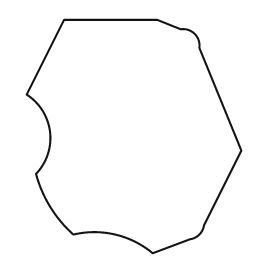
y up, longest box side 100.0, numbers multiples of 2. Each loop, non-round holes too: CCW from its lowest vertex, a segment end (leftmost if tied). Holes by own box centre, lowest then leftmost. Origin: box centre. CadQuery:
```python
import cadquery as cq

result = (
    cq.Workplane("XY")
    .moveTo(8.0, -50.0)
    .lineTo(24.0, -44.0)
    .threePointArc((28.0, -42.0), (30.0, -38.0))
    .lineTo(46.0, -6.0)
    .lineTo(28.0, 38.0)
    .threePointArc((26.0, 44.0), (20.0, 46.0))
    .lineTo(10.0, 50.0)
    .lineTo(-30.0, 50.0)
    .lineTo(-46.0, 18.0)
    .threePointArc((-36.0, 2.0), (-42.0, -16.0))
    .threePointArc((-36.0, -30.0), (-26.0, -42.0))
    .threePointArc((-8.0, -42.0), (8.0, -50.0))
    .close()
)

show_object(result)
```